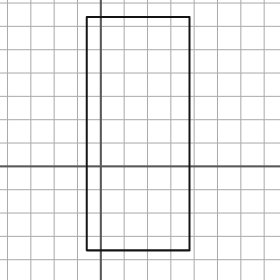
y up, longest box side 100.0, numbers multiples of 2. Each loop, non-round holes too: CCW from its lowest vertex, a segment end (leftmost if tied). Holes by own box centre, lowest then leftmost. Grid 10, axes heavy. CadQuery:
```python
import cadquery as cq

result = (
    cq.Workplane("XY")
    .moveTo(-6.0, -36.0)
    .lineTo(38.0, -36.0)
    .lineTo(38.0, 64.0)
    .lineTo(-6.0, 64.0)
    .close()
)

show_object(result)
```